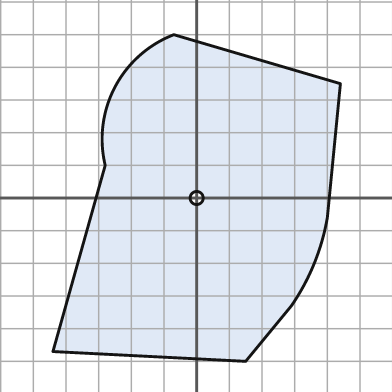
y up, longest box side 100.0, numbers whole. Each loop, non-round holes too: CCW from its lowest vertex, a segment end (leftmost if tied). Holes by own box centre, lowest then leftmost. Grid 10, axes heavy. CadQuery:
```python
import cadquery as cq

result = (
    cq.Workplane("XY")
    .moveTo(15.0, -50.0)
    .lineTo(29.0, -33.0)
    .threePointArc((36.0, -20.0), (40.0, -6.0))
    .lineTo(44.0, 35.0)
    .lineTo(-7.0, 50.0)
    .threePointArc((-25.0, 34.0), (-28.0, 10.0))
    .lineTo(-44.0, -47.0)
    .close()
    .moveTo(0.0, 0.0)
    .circle(2.0)
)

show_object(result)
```